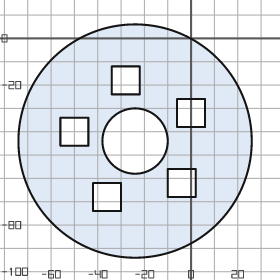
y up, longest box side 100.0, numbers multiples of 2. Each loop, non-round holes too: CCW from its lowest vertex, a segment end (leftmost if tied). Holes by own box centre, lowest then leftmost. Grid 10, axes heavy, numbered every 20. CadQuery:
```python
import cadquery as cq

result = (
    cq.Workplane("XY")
    .moveTo(-24.0, -44.0)
    .circle(50.0)
    .moveTo(-42.0, -74.0)
    .lineTo(-30.0, -74.0)
    .lineTo(-30.0, -62.0)
    .lineTo(-42.0, -62.0)
    .close()
    .moveTo(-10.0, -68.0)
    .lineTo(2.0, -68.0)
    .lineTo(2.0, -56.0)
    .lineTo(-10.0, -56.0)
    .close()
    .moveTo(-24.0, -44.0)
    .circle(14.0)
    .moveTo(-56.0, -46.0)
    .lineTo(-44.0, -46.0)
    .lineTo(-44.0, -34.0)
    .lineTo(-56.0, -34.0)
    .close()
    .moveTo(-6.0, -38.0)
    .lineTo(6.0, -38.0)
    .lineTo(6.0, -26.0)
    .lineTo(-6.0, -26.0)
    .close()
    .moveTo(-34.0, -24.0)
    .lineTo(-22.0, -24.0)
    .lineTo(-22.0, -12.0)
    .lineTo(-34.0, -12.0)
    .close()
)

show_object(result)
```